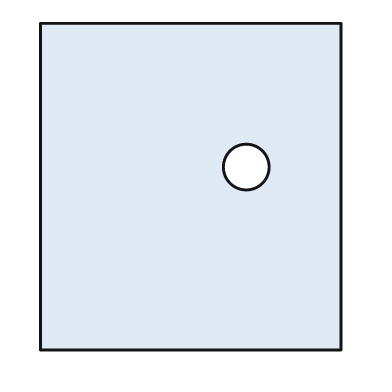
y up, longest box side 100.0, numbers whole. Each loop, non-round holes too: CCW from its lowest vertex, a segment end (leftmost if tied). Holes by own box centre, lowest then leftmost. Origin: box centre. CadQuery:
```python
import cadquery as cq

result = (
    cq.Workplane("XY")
    .moveTo(-46.0, -50.0)
    .lineTo(46.0, -50.0)
    .lineTo(46.0, 50.0)
    .lineTo(-46.0, 50.0)
    .close()
    .moveTo(17.0, 6.0)
    .circle(7.0)
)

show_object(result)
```